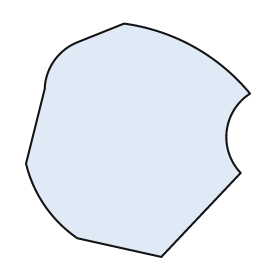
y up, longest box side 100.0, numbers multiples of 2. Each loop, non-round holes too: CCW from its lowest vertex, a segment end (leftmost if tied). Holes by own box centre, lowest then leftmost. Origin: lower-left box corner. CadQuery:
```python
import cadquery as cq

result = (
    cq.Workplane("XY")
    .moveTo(58.0, 0.0)
    .lineTo(92.0, 36.0)
    .threePointArc((86.0, 54.0), (96.0, 70.0))
    .threePointArc((72.0, 90.0), (42.0, 100.0))
    .lineTo(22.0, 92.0)
    .threePointArc((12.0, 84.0), (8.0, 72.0))
    .lineTo(0.0, 40.0)
    .threePointArc((8.0, 22.0), (22.0, 8.0))
    .close()
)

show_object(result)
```